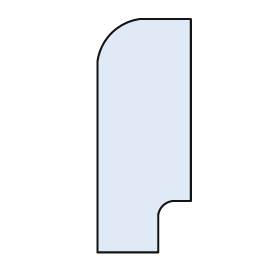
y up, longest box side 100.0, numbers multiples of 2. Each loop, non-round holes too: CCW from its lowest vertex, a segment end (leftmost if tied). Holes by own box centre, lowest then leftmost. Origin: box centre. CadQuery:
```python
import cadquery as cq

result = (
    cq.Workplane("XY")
    .moveTo(-20.0, -50.0)
    .lineTo(6.0, -50.0)
    .lineTo(6.0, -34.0)
    .threePointArc((8.0, -30.0), (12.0, -28.0))
    .lineTo(20.0, -28.0)
    .lineTo(20.0, 50.0)
    .lineTo(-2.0, 50.0)
    .threePointArc((-14.0, 44.0), (-20.0, 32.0))
    .close()
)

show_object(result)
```